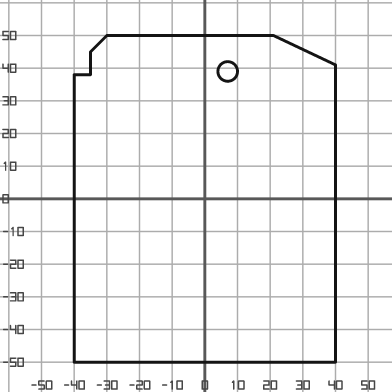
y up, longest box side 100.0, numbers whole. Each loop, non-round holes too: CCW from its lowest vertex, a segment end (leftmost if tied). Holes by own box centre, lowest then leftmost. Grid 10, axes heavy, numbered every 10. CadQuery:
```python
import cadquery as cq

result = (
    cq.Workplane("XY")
    .moveTo(-40.0, -50.0)
    .lineTo(40.0, -50.0)
    .lineTo(40.0, 41.0)
    .lineTo(21.0, 50.0)
    .lineTo(-30.0, 50.0)
    .lineTo(-35.0, 45.0)
    .lineTo(-35.0, 38.0)
    .lineTo(-40.0, 38.0)
    .close()
    .moveTo(7.0, 39.0)
    .circle(3.0)
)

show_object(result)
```